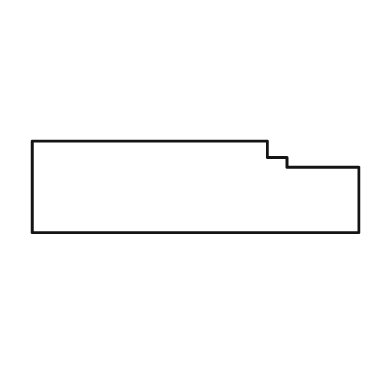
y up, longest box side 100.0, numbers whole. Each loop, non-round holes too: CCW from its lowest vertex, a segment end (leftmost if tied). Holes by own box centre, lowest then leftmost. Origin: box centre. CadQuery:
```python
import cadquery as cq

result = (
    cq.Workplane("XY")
    .moveTo(-50.0, -14.0)
    .lineTo(50.0, -14.0)
    .lineTo(50.0, 6.0)
    .lineTo(28.0, 6.0)
    .lineTo(28.0, 9.0)
    .lineTo(22.0, 9.0)
    .lineTo(22.0, 14.0)
    .lineTo(-50.0, 14.0)
    .close()
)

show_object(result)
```